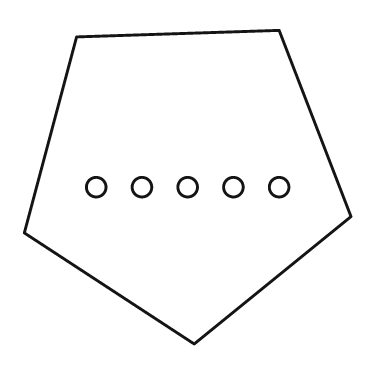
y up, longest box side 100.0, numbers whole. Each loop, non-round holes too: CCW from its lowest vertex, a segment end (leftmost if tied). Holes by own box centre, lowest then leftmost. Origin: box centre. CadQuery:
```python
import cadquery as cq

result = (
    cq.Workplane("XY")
    .moveTo(2.0, -48.0)
    .lineTo(50.0, -9.0)
    .lineTo(28.0, 48.0)
    .lineTo(-34.0, 46.0)
    .lineTo(-50.0, -14.0)
    .close()
    .moveTo(-28.0, 0.0)
    .circle(3.0)
    .moveTo(-14.0, 0.0)
    .circle(3.0)
    .moveTo(0.0, 0.0)
    .circle(3.0)
    .moveTo(14.0, 0.0)
    .circle(3.0)
    .moveTo(28.0, 0.0)
    .circle(3.0)
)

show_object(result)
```